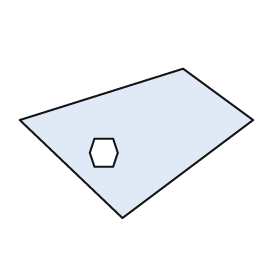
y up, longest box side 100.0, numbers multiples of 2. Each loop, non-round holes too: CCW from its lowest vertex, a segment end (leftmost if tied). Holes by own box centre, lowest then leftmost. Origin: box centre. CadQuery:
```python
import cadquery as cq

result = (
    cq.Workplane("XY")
    .moveTo(-6.0, -32.0)
    .lineTo(50.0, 10.0)
    .lineTo(20.0, 32.0)
    .lineTo(-50.0, 10.0)
    .close()
    .moveTo(-18.0, -10.0)
    .lineTo(-10.0, -10.0)
    .lineTo(-8.0, -4.0)
    .lineTo(-10.0, 2.0)
    .lineTo(-18.0, 2.0)
    .lineTo(-20.0, -4.0)
    .close()
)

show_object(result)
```